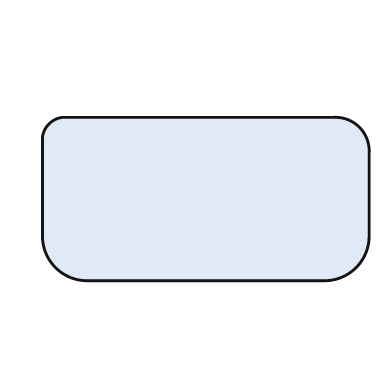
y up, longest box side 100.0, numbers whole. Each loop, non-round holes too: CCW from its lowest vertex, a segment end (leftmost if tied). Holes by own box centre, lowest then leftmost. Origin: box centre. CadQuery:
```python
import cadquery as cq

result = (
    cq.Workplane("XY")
    .moveTo(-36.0, -25.0)
    .lineTo(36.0, -25.0)
    .threePointArc((46.0, -21.0), (50.0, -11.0))
    .lineTo(50.0, 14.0)
    .threePointArc((47.0, 22.0), (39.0, 25.0))
    .lineTo(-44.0, 25.0)
    .threePointArc((-48.0, 23.0), (-50.0, 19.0))
    .lineTo(-50.0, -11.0)
    .threePointArc((-46.0, -21.0), (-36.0, -25.0))
    .close()
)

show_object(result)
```